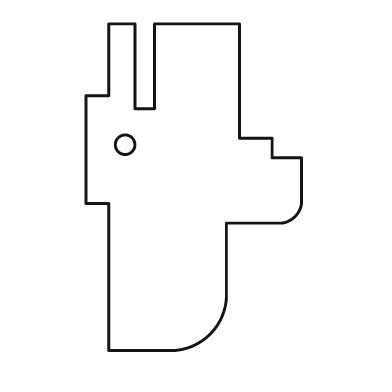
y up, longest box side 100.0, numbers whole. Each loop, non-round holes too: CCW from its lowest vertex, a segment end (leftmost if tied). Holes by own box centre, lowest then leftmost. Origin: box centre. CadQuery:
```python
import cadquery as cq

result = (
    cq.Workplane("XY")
    .moveTo(-26.0, -50.0)
    .lineTo(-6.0, -50.0)
    .threePointArc((5.0, -45.0), (10.0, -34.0))
    .lineTo(10.0, -11.0)
    .lineTo(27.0, -11.0)
    .threePointArc((31.0, -9.0), (33.0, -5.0))
    .lineTo(33.0, 9.0)
    .lineTo(24.0, 9.0)
    .lineTo(24.0, 15.0)
    .lineTo(14.0, 15.0)
    .lineTo(14.0, 50.0)
    .lineTo(-12.0, 50.0)
    .lineTo(-12.0, 24.0)
    .lineTo(-18.0, 24.0)
    .lineTo(-18.0, 50.0)
    .lineTo(-26.0, 50.0)
    .lineTo(-26.0, 28.0)
    .lineTo(-33.0, 28.0)
    .lineTo(-33.0, -5.0)
    .lineTo(-26.0, -5.0)
    .close()
    .moveTo(-21.0, 13.0)
    .circle(3.0)
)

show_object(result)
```